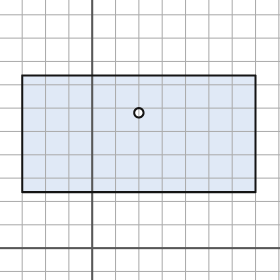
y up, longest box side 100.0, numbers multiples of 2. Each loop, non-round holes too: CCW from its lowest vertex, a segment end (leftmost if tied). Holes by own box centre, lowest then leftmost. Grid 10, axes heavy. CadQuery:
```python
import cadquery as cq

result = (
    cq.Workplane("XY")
    .moveTo(-30.0, 24.0)
    .lineTo(70.0, 24.0)
    .lineTo(70.0, 74.0)
    .lineTo(-30.0, 74.0)
    .close()
    .moveTo(20.0, 58.0)
    .circle(2.0)
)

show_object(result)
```